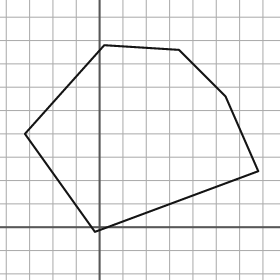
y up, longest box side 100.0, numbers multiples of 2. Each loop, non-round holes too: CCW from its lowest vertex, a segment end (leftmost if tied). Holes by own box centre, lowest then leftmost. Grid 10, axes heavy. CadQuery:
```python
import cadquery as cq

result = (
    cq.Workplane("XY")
    .moveTo(-2.0, -2.0)
    .lineTo(68.0, 24.0)
    .lineTo(54.0, 56.0)
    .lineTo(34.0, 76.0)
    .lineTo(2.0, 78.0)
    .lineTo(-32.0, 40.0)
    .close()
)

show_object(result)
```